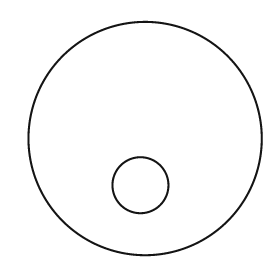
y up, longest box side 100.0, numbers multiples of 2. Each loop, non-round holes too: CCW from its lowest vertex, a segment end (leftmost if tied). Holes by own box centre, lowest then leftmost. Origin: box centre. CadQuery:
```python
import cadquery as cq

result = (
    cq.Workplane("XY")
    .moveTo(0.0, 0.0)
    .circle(50.0)
    .moveTo(-2.0, -20.0)
    .circle(12.0)
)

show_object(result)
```